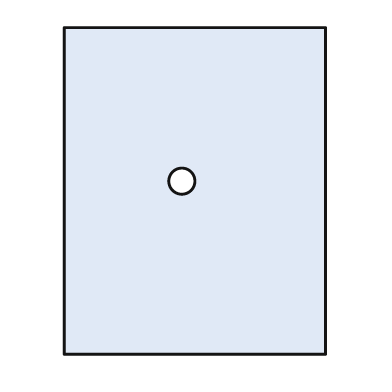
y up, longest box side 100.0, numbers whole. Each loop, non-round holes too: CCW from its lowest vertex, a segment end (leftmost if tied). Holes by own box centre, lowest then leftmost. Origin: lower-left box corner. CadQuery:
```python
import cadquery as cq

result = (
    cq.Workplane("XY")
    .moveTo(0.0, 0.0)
    .lineTo(80.0, 0.0)
    .lineTo(80.0, 100.0)
    .lineTo(0.0, 100.0)
    .close()
    .moveTo(36.0, 53.0)
    .circle(4.0)
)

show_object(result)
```